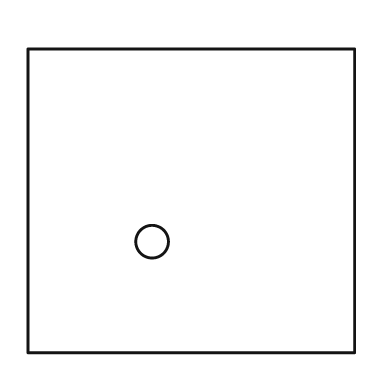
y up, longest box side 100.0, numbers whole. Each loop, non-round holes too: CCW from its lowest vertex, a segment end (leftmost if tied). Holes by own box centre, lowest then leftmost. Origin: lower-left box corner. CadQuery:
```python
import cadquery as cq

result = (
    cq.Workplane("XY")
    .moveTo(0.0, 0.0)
    .lineTo(100.0, 0.0)
    .lineTo(100.0, 93.0)
    .lineTo(0.0, 93.0)
    .close()
    .moveTo(38.0, 34.0)
    .circle(5.0)
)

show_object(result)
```